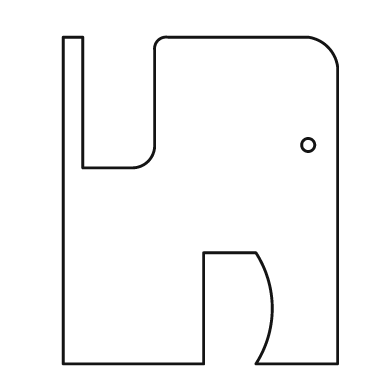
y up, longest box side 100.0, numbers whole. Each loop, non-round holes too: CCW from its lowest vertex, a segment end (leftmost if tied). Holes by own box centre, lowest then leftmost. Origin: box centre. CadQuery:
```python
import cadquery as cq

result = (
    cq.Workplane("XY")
    .moveTo(-42.0, -50.0)
    .lineTo(1.0, -50.0)
    .lineTo(1.0, -16.0)
    .lineTo(17.0, -16.0)
    .threePointArc((22.0, -33.0), (17.0, -50.0))
    .lineTo(42.0, -50.0)
    .lineTo(42.0, 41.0)
    .threePointArc((39.0, 47.0), (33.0, 50.0))
    .lineTo(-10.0, 50.0)
    .threePointArc((-13.0, 49.0), (-14.0, 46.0))
    .lineTo(-14.0, 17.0)
    .threePointArc((-16.0, 12.0), (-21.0, 10.0))
    .lineTo(-36.0, 10.0)
    .lineTo(-36.0, 50.0)
    .lineTo(-42.0, 50.0)
    .close()
    .moveTo(33.0, 17.0)
    .circle(2.0)
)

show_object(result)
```